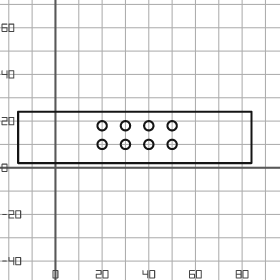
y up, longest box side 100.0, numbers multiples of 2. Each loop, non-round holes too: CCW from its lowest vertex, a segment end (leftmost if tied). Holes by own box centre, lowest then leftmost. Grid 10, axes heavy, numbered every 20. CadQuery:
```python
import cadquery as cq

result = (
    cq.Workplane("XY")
    .moveTo(-16.0, 2.0)
    .lineTo(84.0, 2.0)
    .lineTo(84.0, 24.0)
    .lineTo(-16.0, 24.0)
    .close()
    .moveTo(20.0, 10.0)
    .circle(2.0)
    .moveTo(30.0, 10.0)
    .circle(2.0)
    .moveTo(40.0, 10.0)
    .circle(2.0)
    .moveTo(50.0, 10.0)
    .circle(2.0)
    .moveTo(20.0, 18.0)
    .circle(2.0)
    .moveTo(30.0, 18.0)
    .circle(2.0)
    .moveTo(40.0, 18.0)
    .circle(2.0)
    .moveTo(50.0, 18.0)
    .circle(2.0)
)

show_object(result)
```